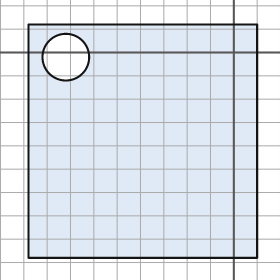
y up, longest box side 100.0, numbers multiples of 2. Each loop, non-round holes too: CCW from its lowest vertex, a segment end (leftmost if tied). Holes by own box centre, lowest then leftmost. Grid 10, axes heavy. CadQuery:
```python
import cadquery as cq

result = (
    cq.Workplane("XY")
    .moveTo(-88.0, -88.0)
    .lineTo(10.0, -88.0)
    .lineTo(10.0, 12.0)
    .lineTo(-88.0, 12.0)
    .close()
    .moveTo(-72.0, -2.0)
    .circle(10.0)
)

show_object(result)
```